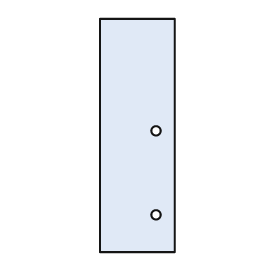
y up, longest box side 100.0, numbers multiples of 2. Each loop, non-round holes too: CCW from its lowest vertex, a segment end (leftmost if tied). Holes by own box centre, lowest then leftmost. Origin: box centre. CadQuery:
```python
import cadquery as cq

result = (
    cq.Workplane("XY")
    .moveTo(-16.0, -50.0)
    .lineTo(16.0, -50.0)
    .lineTo(16.0, 50.0)
    .lineTo(-16.0, 50.0)
    .close()
    .moveTo(8.0, -34.0)
    .circle(2.0)
    .moveTo(8.0, 2.0)
    .circle(2.0)
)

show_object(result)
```